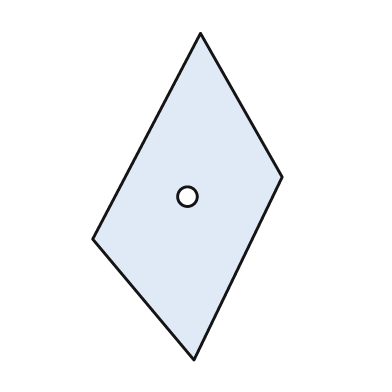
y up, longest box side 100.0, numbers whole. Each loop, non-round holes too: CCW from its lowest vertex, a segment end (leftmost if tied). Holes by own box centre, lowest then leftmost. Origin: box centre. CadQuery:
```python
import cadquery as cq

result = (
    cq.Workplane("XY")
    .moveTo(2.0, -50.0)
    .lineTo(29.0, 6.0)
    .lineTo(4.0, 50.0)
    .lineTo(-29.0, -13.0)
    .close()
    .moveTo(0.0, 0.0)
    .circle(3.0)
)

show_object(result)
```